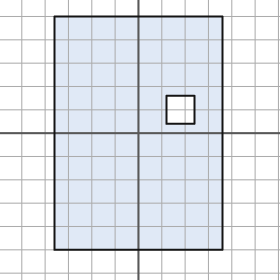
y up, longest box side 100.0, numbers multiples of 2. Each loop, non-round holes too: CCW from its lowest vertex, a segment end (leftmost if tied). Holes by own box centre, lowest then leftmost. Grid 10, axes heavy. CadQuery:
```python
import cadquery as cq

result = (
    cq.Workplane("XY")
    .moveTo(-36.0, -50.0)
    .lineTo(36.0, -50.0)
    .lineTo(36.0, 50.0)
    .lineTo(-36.0, 50.0)
    .close()
    .moveTo(12.0, 4.0)
    .lineTo(24.0, 4.0)
    .lineTo(24.0, 16.0)
    .lineTo(12.0, 16.0)
    .close()
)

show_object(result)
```